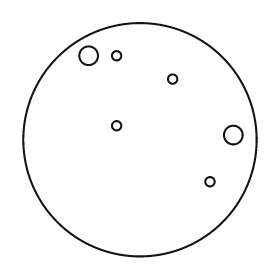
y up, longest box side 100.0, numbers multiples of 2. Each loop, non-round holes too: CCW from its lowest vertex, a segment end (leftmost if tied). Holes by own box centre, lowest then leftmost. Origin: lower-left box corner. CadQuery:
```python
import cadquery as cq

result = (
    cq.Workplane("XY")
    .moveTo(50.0, 50.0)
    .circle(50.0)
    .moveTo(80.0, 32.0)
    .circle(2.0)
    .moveTo(90.0, 52.0)
    .circle(4.0)
    .moveTo(40.0, 56.0)
    .circle(2.0)
    .moveTo(64.0, 76.0)
    .circle(2.0)
    .moveTo(28.0, 86.0)
    .circle(4.0)
    .moveTo(40.0, 86.0)
    .circle(2.0)
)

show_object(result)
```